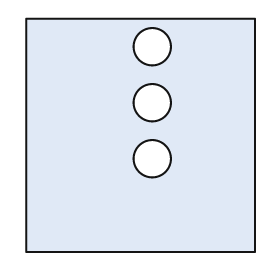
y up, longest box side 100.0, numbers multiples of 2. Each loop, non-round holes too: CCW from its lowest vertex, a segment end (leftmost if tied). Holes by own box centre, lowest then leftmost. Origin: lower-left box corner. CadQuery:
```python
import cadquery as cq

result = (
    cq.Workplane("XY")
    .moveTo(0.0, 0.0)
    .lineTo(98.0, 0.0)
    .lineTo(98.0, 100.0)
    .lineTo(0.0, 100.0)
    .close()
    .moveTo(54.0, 40.0)
    .circle(8.0)
    .moveTo(54.0, 64.0)
    .circle(8.0)
    .moveTo(54.0, 88.0)
    .circle(8.0)
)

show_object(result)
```